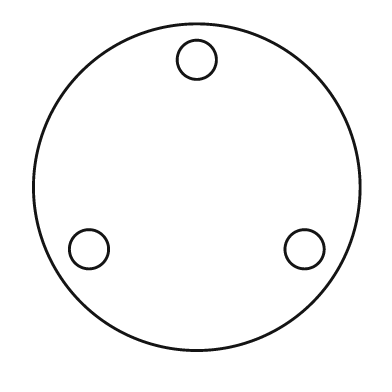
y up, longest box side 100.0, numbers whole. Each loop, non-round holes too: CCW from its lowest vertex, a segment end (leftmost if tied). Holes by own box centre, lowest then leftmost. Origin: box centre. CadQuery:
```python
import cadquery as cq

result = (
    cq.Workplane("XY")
    .moveTo(0.0, 0.0)
    .circle(50.0)
    .moveTo(-33.0, -19.0)
    .circle(6.0)
    .moveTo(33.0, -19.0)
    .circle(6.0)
    .moveTo(0.0, 39.0)
    .circle(6.0)
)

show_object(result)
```